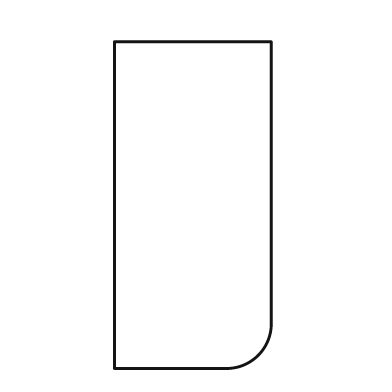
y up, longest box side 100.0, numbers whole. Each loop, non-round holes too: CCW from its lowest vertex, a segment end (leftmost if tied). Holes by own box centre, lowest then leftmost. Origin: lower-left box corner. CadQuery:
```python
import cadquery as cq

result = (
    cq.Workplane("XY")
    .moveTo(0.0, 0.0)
    .lineTo(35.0, 0.0)
    .threePointArc((44.0, 4.0), (48.0, 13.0))
    .lineTo(48.0, 100.0)
    .lineTo(0.0, 100.0)
    .close()
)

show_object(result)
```